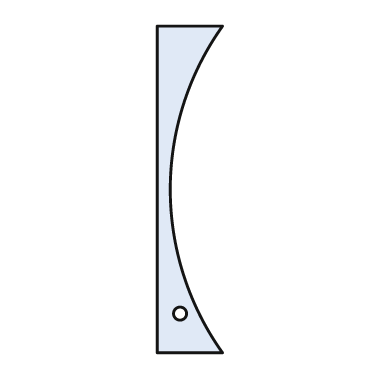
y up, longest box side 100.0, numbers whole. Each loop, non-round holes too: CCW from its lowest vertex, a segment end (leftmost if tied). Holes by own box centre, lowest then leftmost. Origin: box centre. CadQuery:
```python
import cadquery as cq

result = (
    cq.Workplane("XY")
    .moveTo(-10.0, -50.0)
    .lineTo(10.0, -50.0)
    .threePointArc((-6.0, 0.0), (10.0, 50.0))
    .lineTo(-10.0, 50.0)
    .close()
    .moveTo(-3.0, -38.0)
    .circle(2.0)
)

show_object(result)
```